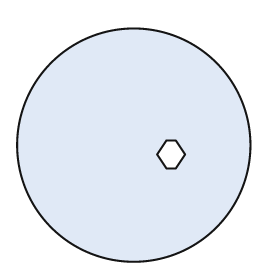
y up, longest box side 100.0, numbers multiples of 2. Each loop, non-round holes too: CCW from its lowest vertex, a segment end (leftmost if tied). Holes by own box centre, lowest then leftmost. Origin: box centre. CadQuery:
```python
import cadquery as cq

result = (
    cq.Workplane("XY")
    .moveTo(0.0, 0.0)
    .circle(50.0)
    .moveTo(14.0, -10.0)
    .lineTo(18.0, -10.0)
    .lineTo(22.0, -4.0)
    .lineTo(18.0, 2.0)
    .lineTo(14.0, 2.0)
    .lineTo(10.0, -4.0)
    .close()
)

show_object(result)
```